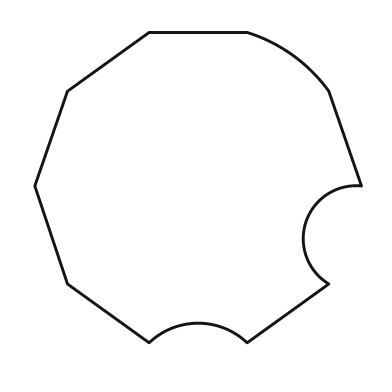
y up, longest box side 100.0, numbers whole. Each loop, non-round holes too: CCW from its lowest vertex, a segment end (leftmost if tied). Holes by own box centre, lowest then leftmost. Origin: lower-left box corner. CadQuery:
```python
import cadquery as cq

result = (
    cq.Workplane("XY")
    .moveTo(35.0, 0.0)
    .threePointArc((50.0, 6.0), (65.0, 0.0))
    .lineTo(90.0, 18.0)
    .threePointArc((83.0, 37.0), (100.0, 48.0))
    .lineTo(90.0, 77.0)
    .threePointArc((79.0, 88.0), (65.0, 95.0))
    .lineTo(35.0, 95.0)
    .lineTo(10.0, 77.0)
    .lineTo(0.0, 48.0)
    .lineTo(10.0, 18.0)
    .close()
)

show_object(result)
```